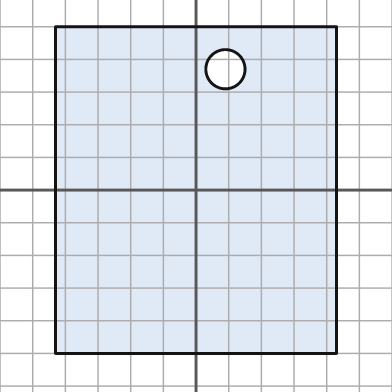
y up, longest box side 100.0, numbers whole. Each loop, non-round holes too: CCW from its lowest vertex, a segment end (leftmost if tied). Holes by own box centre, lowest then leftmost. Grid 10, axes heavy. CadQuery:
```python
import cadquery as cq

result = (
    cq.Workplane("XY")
    .moveTo(-43.0, -50.0)
    .lineTo(43.0, -50.0)
    .lineTo(43.0, 50.0)
    .lineTo(-43.0, 50.0)
    .close()
    .moveTo(9.0, 37.0)
    .circle(6.0)
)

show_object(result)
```